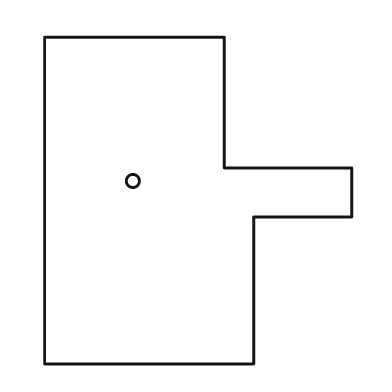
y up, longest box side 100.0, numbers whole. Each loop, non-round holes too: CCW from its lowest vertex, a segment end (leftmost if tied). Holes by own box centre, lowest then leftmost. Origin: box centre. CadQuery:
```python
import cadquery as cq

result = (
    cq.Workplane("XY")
    .moveTo(-47.0, -50.0)
    .lineTo(17.0, -50.0)
    .lineTo(17.0, -5.0)
    .lineTo(47.0, -5.0)
    .lineTo(47.0, 10.0)
    .lineTo(8.0, 10.0)
    .lineTo(8.0, 50.0)
    .lineTo(-47.0, 50.0)
    .close()
    .moveTo(-20.0, 6.0)
    .circle(2.0)
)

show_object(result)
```